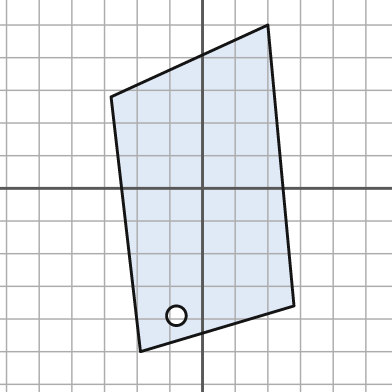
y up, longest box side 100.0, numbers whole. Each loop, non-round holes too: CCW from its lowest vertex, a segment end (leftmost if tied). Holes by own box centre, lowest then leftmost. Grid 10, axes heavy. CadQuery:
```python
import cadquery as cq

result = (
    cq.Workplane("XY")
    .moveTo(-19.0, -50.0)
    .lineTo(28.0, -36.0)
    .lineTo(20.0, 50.0)
    .lineTo(-28.0, 28.0)
    .close()
    .moveTo(-8.0, -39.0)
    .circle(3.0)
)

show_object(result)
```